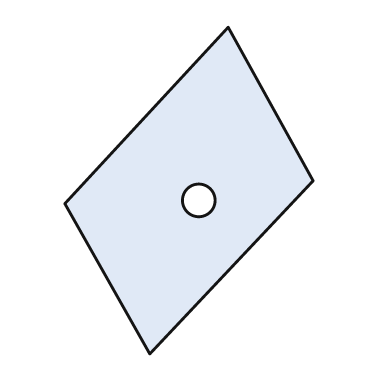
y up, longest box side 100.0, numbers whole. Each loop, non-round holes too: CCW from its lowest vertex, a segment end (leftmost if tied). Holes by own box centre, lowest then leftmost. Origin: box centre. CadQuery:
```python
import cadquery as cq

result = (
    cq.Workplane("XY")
    .moveTo(-12.0, -50.0)
    .lineTo(38.0, 3.0)
    .lineTo(12.0, 50.0)
    .lineTo(-38.0, -4.0)
    .close()
    .moveTo(3.0, -3.0)
    .circle(5.0)
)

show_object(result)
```